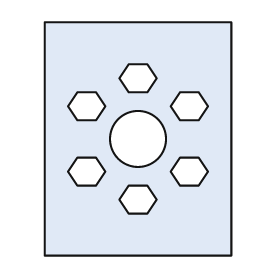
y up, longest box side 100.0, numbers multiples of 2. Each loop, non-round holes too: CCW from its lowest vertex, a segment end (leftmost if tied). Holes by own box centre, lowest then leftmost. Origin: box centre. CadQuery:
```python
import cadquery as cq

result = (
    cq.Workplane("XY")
    .moveTo(-40.0, -50.0)
    .lineTo(40.0, -50.0)
    .lineTo(40.0, 50.0)
    .lineTo(-40.0, 50.0)
    .close()
    .moveTo(-4.0, -32.0)
    .lineTo(4.0, -32.0)
    .lineTo(8.0, -26.0)
    .lineTo(4.0, -20.0)
    .lineTo(-4.0, -20.0)
    .lineTo(-8.0, -26.0)
    .close()
    .moveTo(-26.0, -20.0)
    .lineTo(-18.0, -20.0)
    .lineTo(-14.0, -14.0)
    .lineTo(-18.0, -8.0)
    .lineTo(-26.0, -8.0)
    .lineTo(-30.0, -14.0)
    .close()
    .moveTo(18.0, -20.0)
    .lineTo(26.0, -20.0)
    .lineTo(30.0, -14.0)
    .lineTo(26.0, -8.0)
    .lineTo(18.0, -8.0)
    .lineTo(14.0, -14.0)
    .close()
    .moveTo(0.0, 0.0)
    .circle(12.0)
    .moveTo(-26.0, 8.0)
    .lineTo(-18.0, 8.0)
    .lineTo(-14.0, 14.0)
    .lineTo(-18.0, 20.0)
    .lineTo(-26.0, 20.0)
    .lineTo(-30.0, 14.0)
    .close()
    .moveTo(18.0, 8.0)
    .lineTo(26.0, 8.0)
    .lineTo(30.0, 14.0)
    .lineTo(26.0, 20.0)
    .lineTo(18.0, 20.0)
    .lineTo(14.0, 14.0)
    .close()
    .moveTo(-4.0, 20.0)
    .lineTo(4.0, 20.0)
    .lineTo(8.0, 26.0)
    .lineTo(4.0, 32.0)
    .lineTo(-4.0, 32.0)
    .lineTo(-8.0, 26.0)
    .close()
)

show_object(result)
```